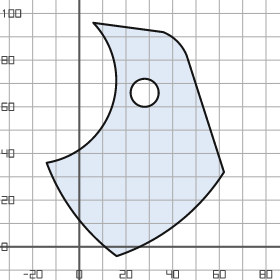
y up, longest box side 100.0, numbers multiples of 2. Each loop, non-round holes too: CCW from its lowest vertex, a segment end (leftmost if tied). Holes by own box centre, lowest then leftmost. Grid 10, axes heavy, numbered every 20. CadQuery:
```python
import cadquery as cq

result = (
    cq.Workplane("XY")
    .moveTo(16.0, -4.0)
    .threePointArc((42.0, 10.0), (62.0, 32.0))
    .lineTo(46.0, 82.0)
    .threePointArc((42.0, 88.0), (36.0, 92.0))
    .lineTo(6.0, 96.0)
    .threePointArc((14.0, 60.0), (-14.0, 36.0))
    .threePointArc((-2.0, 14.0), (16.0, -4.0))
    .close()
    .moveTo(28.0, 66.0)
    .circle(6.0)
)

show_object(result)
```